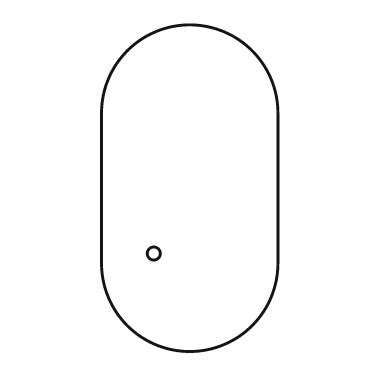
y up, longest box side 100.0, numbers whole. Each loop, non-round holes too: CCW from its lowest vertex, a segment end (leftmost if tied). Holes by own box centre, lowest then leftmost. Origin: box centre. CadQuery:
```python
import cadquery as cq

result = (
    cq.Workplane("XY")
    .moveTo(-27.0, -23.0)
    .threePointArc((0.0, -50.0), (27.0, -23.0))
    .lineTo(27.0, 23.0)
    .threePointArc((0.0, 50.0), (-27.0, 23.0))
    .close()
    .moveTo(-11.0, -20.0)
    .circle(2.0)
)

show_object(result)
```